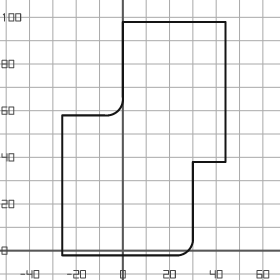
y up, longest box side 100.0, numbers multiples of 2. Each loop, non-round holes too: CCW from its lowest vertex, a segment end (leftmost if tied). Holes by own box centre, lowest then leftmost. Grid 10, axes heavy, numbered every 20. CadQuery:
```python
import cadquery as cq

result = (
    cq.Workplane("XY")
    .moveTo(-26.0, -2.0)
    .lineTo(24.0, -2.0)
    .threePointArc((28.0, 0.0), (30.0, 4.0))
    .lineTo(30.0, 38.0)
    .lineTo(44.0, 38.0)
    .lineTo(44.0, 98.0)
    .lineTo(0.0, 98.0)
    .lineTo(0.0, 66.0)
    .threePointArc((-2.0, 60.0), (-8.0, 58.0))
    .lineTo(-26.0, 58.0)
    .close()
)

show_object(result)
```